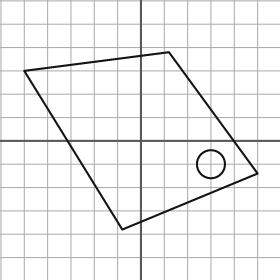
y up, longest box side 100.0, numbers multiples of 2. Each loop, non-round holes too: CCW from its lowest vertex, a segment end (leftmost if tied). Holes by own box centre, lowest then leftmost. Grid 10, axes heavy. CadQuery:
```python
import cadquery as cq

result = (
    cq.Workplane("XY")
    .moveTo(-8.0, -38.0)
    .lineTo(50.0, -14.0)
    .lineTo(12.0, 38.0)
    .lineTo(-50.0, 30.0)
    .close()
    .moveTo(30.0, -10.0)
    .circle(6.0)
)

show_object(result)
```